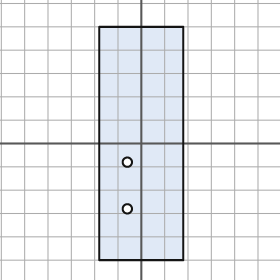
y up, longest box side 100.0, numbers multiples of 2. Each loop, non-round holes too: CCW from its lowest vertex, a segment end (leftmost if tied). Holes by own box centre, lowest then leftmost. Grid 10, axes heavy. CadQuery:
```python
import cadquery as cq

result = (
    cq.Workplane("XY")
    .moveTo(-18.0, -50.0)
    .lineTo(18.0, -50.0)
    .lineTo(18.0, 50.0)
    .lineTo(-18.0, 50.0)
    .close()
    .moveTo(-6.0, -28.0)
    .circle(2.0)
    .moveTo(-6.0, -8.0)
    .circle(2.0)
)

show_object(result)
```